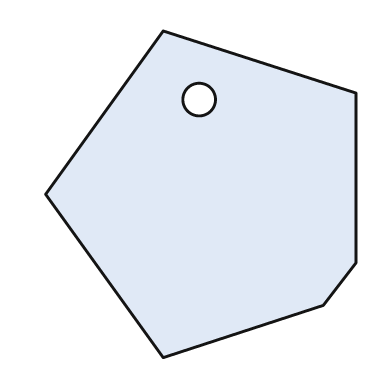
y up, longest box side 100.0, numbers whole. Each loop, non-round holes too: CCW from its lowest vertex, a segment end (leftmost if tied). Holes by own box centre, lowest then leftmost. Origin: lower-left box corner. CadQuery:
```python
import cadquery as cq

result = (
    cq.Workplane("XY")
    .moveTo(36.0, 0.0)
    .lineTo(85.0, 16.0)
    .lineTo(95.0, 29.0)
    .lineTo(95.0, 81.0)
    .lineTo(36.0, 100.0)
    .lineTo(0.0, 50.0)
    .close()
    .moveTo(47.0, 79.0)
    .circle(5.0)
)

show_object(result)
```